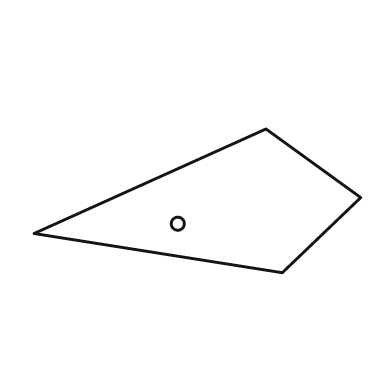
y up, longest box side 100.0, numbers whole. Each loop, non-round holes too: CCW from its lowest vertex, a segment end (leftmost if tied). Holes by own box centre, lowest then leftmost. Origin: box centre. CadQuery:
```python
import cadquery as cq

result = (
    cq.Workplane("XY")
    .moveTo(26.0, -22.0)
    .lineTo(50.0, 1.0)
    .lineTo(21.0, 22.0)
    .lineTo(-50.0, -10.0)
    .close()
    .moveTo(-6.0, -7.0)
    .circle(2.0)
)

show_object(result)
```